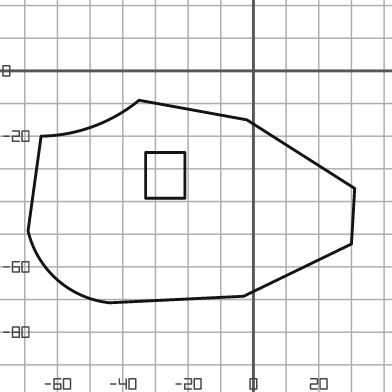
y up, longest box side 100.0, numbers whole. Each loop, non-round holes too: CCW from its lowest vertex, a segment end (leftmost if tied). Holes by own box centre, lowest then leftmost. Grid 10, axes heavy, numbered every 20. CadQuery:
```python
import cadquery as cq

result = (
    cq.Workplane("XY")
    .moveTo(-44.0, -71.0)
    .lineTo(-3.0, -69.0)
    .lineTo(30.0, -53.0)
    .lineTo(31.0, -36.0)
    .lineTo(-2.0, -15.0)
    .lineTo(-35.0, -9.0)
    .threePointArc((-49.0, -17.0), (-65.0, -20.0))
    .lineTo(-69.0, -49.0)
    .threePointArc((-60.0, -64.0), (-44.0, -71.0))
    .close()
    .moveTo(-33.0, -39.0)
    .lineTo(-21.0, -39.0)
    .lineTo(-21.0, -25.0)
    .lineTo(-33.0, -25.0)
    .close()
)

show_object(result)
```